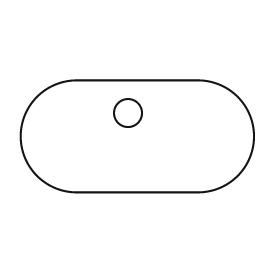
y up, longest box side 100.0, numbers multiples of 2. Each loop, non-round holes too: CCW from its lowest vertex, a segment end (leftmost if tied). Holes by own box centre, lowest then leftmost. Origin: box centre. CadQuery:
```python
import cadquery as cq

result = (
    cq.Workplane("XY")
    .moveTo(-26.0, -24.0)
    .lineTo(26.0, -24.0)
    .threePointArc((50.0, 0.0), (26.0, 24.0))
    .lineTo(-26.0, 24.0)
    .threePointArc((-50.0, 0.0), (-26.0, -24.0))
    .close()
    .moveTo(-4.0, 10.0)
    .circle(6.0)
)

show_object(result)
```